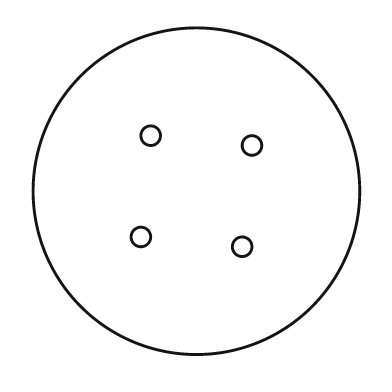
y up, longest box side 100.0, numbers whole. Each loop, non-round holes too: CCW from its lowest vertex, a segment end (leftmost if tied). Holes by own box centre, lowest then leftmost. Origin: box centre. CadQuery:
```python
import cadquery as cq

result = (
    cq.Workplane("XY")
    .moveTo(0.0, 0.0)
    .circle(50.0)
    .moveTo(14.0, -17.0)
    .circle(3.0)
    .moveTo(-17.0, -14.0)
    .circle(3.0)
    .moveTo(17.0, 14.0)
    .circle(3.0)
    .moveTo(-14.0, 17.0)
    .circle(3.0)
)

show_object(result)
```